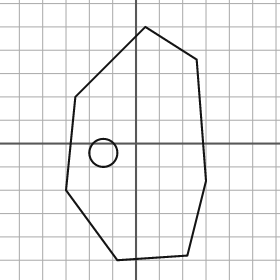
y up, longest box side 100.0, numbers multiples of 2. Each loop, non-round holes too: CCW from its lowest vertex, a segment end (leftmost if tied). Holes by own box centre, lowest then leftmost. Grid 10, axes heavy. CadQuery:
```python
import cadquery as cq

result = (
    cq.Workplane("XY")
    .moveTo(-8.0, -50.0)
    .lineTo(22.0, -48.0)
    .lineTo(30.0, -16.0)
    .lineTo(26.0, 36.0)
    .lineTo(4.0, 50.0)
    .lineTo(-26.0, 20.0)
    .lineTo(-30.0, -20.0)
    .close()
    .moveTo(-14.0, -4.0)
    .circle(6.0)
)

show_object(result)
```